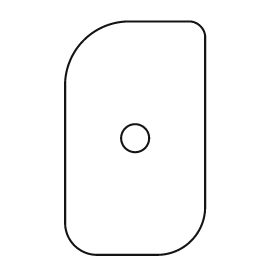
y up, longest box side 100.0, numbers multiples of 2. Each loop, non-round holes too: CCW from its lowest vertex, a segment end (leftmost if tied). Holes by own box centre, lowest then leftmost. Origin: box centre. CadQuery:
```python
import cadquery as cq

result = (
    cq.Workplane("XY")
    .moveTo(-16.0, -50.0)
    .lineTo(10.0, -50.0)
    .threePointArc((24.0, -44.0), (30.0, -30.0))
    .lineTo(30.0, 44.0)
    .threePointArc((28.0, 48.0), (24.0, 50.0))
    .lineTo(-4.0, 50.0)
    .threePointArc((-22.0, 42.0), (-30.0, 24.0))
    .lineTo(-30.0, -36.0)
    .threePointArc((-26.0, -46.0), (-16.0, -50.0))
    .close()
    .moveTo(0.0, 0.0)
    .circle(6.0)
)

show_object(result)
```